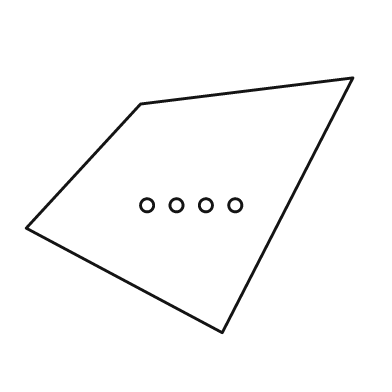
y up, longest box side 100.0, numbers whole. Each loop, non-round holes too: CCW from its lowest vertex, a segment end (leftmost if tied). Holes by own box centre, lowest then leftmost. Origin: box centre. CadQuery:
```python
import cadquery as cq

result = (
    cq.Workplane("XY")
    .moveTo(10.0, -39.0)
    .lineTo(50.0, 39.0)
    .lineTo(-15.0, 31.0)
    .lineTo(-50.0, -7.0)
    .close()
    .moveTo(-13.0, 0.0)
    .circle(2.0)
    .moveTo(-4.0, 0.0)
    .circle(2.0)
    .moveTo(5.0, 0.0)
    .circle(2.0)
    .moveTo(14.0, 0.0)
    .circle(2.0)
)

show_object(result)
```